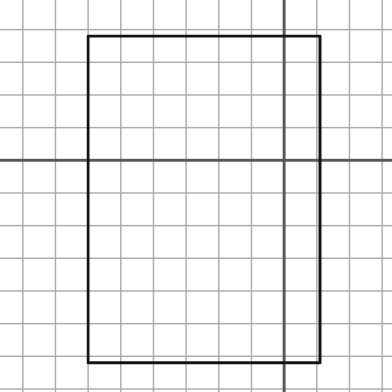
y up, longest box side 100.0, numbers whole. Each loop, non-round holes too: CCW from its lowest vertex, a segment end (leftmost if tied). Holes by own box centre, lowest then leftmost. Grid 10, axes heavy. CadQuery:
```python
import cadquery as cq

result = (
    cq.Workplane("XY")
    .moveTo(-60.0, -62.0)
    .lineTo(11.0, -62.0)
    .lineTo(11.0, 38.0)
    .lineTo(-60.0, 38.0)
    .close()
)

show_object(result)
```